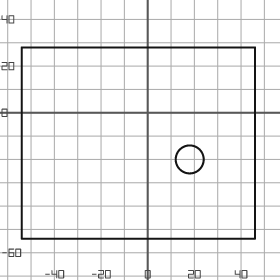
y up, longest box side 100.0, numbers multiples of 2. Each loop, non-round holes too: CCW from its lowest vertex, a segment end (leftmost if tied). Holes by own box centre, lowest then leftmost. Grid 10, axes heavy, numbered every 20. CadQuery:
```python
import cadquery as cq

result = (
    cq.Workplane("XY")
    .moveTo(-54.0, -54.0)
    .lineTo(46.0, -54.0)
    .lineTo(46.0, 28.0)
    .lineTo(-54.0, 28.0)
    .close()
    .moveTo(18.0, -20.0)
    .circle(6.0)
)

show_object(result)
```